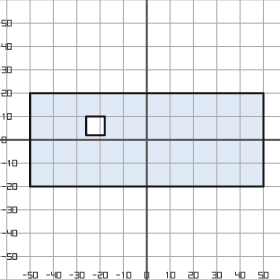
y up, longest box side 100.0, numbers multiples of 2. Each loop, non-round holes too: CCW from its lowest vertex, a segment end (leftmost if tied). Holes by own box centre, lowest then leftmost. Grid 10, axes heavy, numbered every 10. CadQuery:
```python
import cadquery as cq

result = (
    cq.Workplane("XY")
    .moveTo(-50.0, -20.0)
    .lineTo(50.0, -20.0)
    .lineTo(50.0, 20.0)
    .lineTo(-50.0, 20.0)
    .close()
    .moveTo(-26.0, 2.0)
    .lineTo(-18.0, 2.0)
    .lineTo(-18.0, 10.0)
    .lineTo(-26.0, 10.0)
    .close()
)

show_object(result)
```